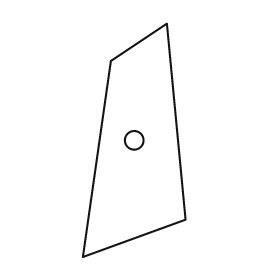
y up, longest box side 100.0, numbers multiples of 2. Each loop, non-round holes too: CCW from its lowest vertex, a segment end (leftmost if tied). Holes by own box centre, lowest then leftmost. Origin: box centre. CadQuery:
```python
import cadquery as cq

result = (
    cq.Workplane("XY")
    .moveTo(-22.0, -50.0)
    .lineTo(22.0, -34.0)
    .lineTo(14.0, 50.0)
    .lineTo(-10.0, 34.0)
    .close()
    .moveTo(0.0, 0.0)
    .circle(4.0)
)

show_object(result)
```